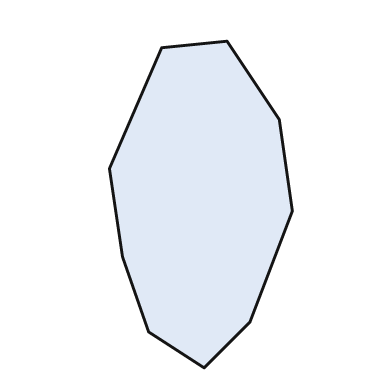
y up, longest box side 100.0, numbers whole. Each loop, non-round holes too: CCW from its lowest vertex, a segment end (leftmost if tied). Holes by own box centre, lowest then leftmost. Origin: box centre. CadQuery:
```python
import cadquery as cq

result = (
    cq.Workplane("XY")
    .moveTo(1.0, -50.0)
    .lineTo(15.0, -36.0)
    .lineTo(28.0, -2.0)
    .lineTo(24.0, 26.0)
    .lineTo(8.0, 50.0)
    .lineTo(-12.0, 48.0)
    .lineTo(-28.0, 11.0)
    .lineTo(-24.0, -16.0)
    .lineTo(-16.0, -39.0)
    .close()
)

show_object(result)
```